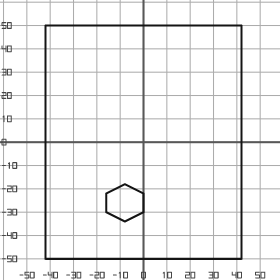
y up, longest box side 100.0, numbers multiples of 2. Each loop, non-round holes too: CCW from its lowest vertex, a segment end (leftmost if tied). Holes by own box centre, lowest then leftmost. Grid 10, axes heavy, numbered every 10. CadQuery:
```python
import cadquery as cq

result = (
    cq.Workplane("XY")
    .moveTo(-42.0, -50.0)
    .lineTo(42.0, -50.0)
    .lineTo(42.0, 50.0)
    .lineTo(-42.0, 50.0)
    .close()
    .moveTo(-8.0, -34.0)
    .lineTo(0.0, -30.0)
    .lineTo(0.0, -22.0)
    .lineTo(-8.0, -18.0)
    .lineTo(-16.0, -22.0)
    .lineTo(-16.0, -30.0)
    .close()
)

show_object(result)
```